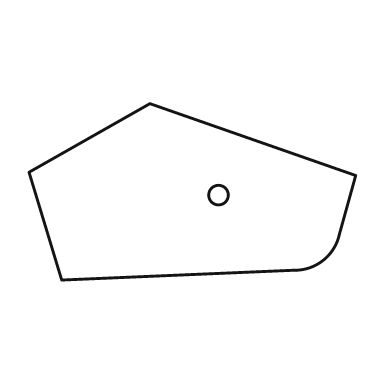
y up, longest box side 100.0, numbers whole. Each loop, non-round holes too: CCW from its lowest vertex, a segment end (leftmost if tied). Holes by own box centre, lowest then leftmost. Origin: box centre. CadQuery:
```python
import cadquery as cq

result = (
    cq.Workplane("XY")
    .moveTo(-40.0, -27.0)
    .lineTo(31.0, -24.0)
    .threePointArc((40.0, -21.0), (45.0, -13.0))
    .lineTo(50.0, 5.0)
    .lineTo(-13.0, 27.0)
    .lineTo(-50.0, 6.0)
    .close()
    .moveTo(8.0, -1.0)
    .circle(3.0)
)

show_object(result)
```